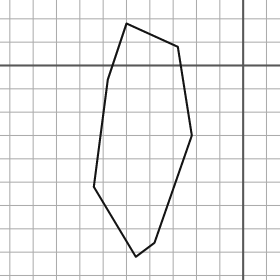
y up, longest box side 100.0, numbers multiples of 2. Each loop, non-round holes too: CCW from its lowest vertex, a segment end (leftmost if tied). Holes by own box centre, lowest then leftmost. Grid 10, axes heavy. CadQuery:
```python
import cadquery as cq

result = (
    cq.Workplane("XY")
    .moveTo(-46.0, -82.0)
    .lineTo(-38.0, -76.0)
    .lineTo(-22.0, -30.0)
    .lineTo(-28.0, 8.0)
    .lineTo(-50.0, 18.0)
    .lineTo(-58.0, -6.0)
    .lineTo(-64.0, -52.0)
    .close()
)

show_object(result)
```